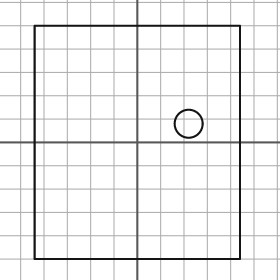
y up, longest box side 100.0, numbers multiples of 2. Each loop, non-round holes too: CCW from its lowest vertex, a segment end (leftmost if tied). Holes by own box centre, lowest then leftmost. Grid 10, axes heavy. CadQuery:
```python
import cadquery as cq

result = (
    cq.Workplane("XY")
    .moveTo(-44.0, -50.0)
    .lineTo(44.0, -50.0)
    .lineTo(44.0, 50.0)
    .lineTo(-44.0, 50.0)
    .close()
    .moveTo(22.0, 8.0)
    .circle(6.0)
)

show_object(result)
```